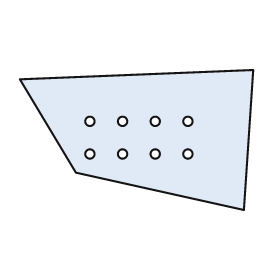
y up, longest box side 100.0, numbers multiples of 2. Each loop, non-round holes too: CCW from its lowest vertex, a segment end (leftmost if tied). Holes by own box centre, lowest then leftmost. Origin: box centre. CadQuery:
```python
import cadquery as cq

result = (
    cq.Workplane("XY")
    .moveTo(46.0, -30.0)
    .lineTo(50.0, 30.0)
    .lineTo(-50.0, 26.0)
    .lineTo(-26.0, -14.0)
    .close()
    .moveTo(-20.0, -6.0)
    .circle(2.0)
    .moveTo(-6.0, -6.0)
    .circle(2.0)
    .moveTo(8.0, -6.0)
    .circle(2.0)
    .moveTo(22.0, -6.0)
    .circle(2.0)
    .moveTo(-20.0, 8.0)
    .circle(2.0)
    .moveTo(-6.0, 8.0)
    .circle(2.0)
    .moveTo(8.0, 8.0)
    .circle(2.0)
    .moveTo(22.0, 8.0)
    .circle(2.0)
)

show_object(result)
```